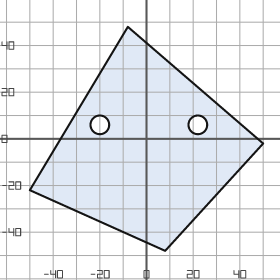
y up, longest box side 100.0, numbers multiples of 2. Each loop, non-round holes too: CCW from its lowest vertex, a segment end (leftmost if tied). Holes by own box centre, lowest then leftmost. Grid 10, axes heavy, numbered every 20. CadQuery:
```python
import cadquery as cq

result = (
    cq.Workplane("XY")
    .moveTo(8.0, -48.0)
    .lineTo(50.0, -2.0)
    .lineTo(-8.0, 48.0)
    .lineTo(-50.0, -22.0)
    .close()
    .moveTo(-20.0, 6.0)
    .circle(4.0)
    .moveTo(22.0, 6.0)
    .circle(4.0)
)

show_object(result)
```